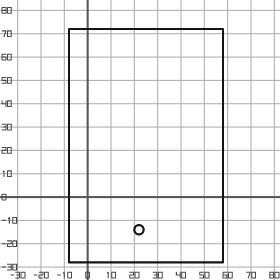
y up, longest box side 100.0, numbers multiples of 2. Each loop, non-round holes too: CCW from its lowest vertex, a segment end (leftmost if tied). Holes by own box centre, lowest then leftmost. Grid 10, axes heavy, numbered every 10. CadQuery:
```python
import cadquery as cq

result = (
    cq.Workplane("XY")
    .moveTo(-8.0, -28.0)
    .lineTo(58.0, -28.0)
    .lineTo(58.0, 72.0)
    .lineTo(-8.0, 72.0)
    .close()
    .moveTo(22.0, -14.0)
    .circle(2.0)
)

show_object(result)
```